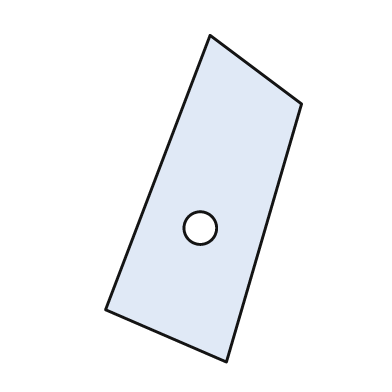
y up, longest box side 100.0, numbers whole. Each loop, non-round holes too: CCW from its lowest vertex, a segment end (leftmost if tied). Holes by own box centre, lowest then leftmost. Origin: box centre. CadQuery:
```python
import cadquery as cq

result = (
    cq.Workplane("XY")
    .moveTo(7.0, -50.0)
    .lineTo(30.0, 29.0)
    .lineTo(2.0, 50.0)
    .lineTo(-30.0, -34.0)
    .close()
    .moveTo(-1.0, -9.0)
    .circle(5.0)
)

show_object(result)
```